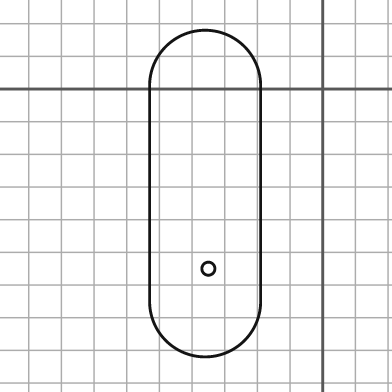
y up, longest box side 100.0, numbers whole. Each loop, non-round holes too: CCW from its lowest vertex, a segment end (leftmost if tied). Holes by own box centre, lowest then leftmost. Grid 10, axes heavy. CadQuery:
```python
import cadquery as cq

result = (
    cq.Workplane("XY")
    .moveTo(-53.0, -65.0)
    .threePointArc((-36.0, -82.0), (-19.0, -65.0))
    .lineTo(-19.0, 1.0)
    .threePointArc((-36.0, 18.0), (-53.0, 1.0))
    .close()
    .moveTo(-35.0, -55.0)
    .circle(2.0)
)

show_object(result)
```